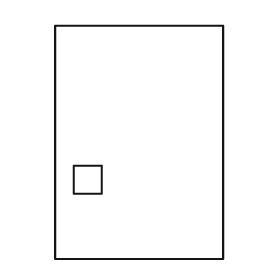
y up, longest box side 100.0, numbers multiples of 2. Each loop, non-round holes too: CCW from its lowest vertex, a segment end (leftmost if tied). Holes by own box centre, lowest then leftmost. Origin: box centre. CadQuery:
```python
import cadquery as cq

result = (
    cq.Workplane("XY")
    .moveTo(-36.0, -50.0)
    .lineTo(36.0, -50.0)
    .lineTo(36.0, 50.0)
    .lineTo(-36.0, 50.0)
    .close()
    .moveTo(-28.0, -22.0)
    .lineTo(-16.0, -22.0)
    .lineTo(-16.0, -10.0)
    .lineTo(-28.0, -10.0)
    .close()
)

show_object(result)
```